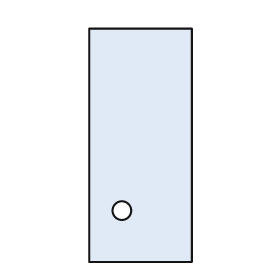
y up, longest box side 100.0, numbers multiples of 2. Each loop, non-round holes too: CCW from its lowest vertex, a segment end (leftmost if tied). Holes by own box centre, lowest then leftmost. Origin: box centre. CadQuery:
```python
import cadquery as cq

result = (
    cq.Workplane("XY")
    .moveTo(-22.0, -50.0)
    .lineTo(22.0, -50.0)
    .lineTo(22.0, 50.0)
    .lineTo(-22.0, 50.0)
    .close()
    .moveTo(-8.0, -28.0)
    .circle(4.0)
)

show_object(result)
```